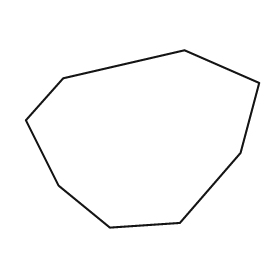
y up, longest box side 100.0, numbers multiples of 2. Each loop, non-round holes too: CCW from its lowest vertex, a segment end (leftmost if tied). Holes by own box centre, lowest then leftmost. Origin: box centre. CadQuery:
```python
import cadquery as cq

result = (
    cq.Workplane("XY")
    .moveTo(-14.0, -38.0)
    .lineTo(16.0, -36.0)
    .lineTo(42.0, -6.0)
    .lineTo(50.0, 24.0)
    .lineTo(18.0, 38.0)
    .lineTo(-34.0, 26.0)
    .lineTo(-50.0, 8.0)
    .lineTo(-36.0, -20.0)
    .close()
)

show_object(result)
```